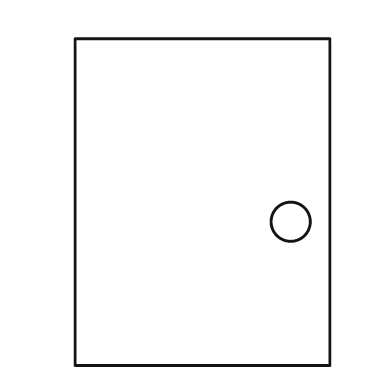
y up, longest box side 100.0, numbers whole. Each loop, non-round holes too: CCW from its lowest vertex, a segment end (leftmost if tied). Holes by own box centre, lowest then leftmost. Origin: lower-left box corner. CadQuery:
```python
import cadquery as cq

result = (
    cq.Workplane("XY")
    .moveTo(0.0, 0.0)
    .lineTo(78.0, 0.0)
    .lineTo(78.0, 100.0)
    .lineTo(0.0, 100.0)
    .close()
    .moveTo(66.0, 44.0)
    .circle(6.0)
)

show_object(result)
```